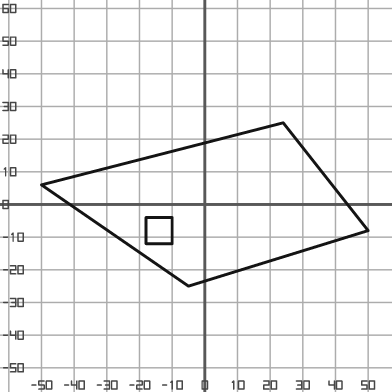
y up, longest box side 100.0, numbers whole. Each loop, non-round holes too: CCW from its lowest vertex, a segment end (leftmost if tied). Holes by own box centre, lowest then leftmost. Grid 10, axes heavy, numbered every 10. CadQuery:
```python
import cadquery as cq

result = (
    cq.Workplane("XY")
    .moveTo(-5.0, -25.0)
    .lineTo(50.0, -8.0)
    .lineTo(24.0, 25.0)
    .lineTo(-50.0, 6.0)
    .close()
    .moveTo(-18.0, -12.0)
    .lineTo(-10.0, -12.0)
    .lineTo(-10.0, -4.0)
    .lineTo(-18.0, -4.0)
    .close()
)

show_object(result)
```